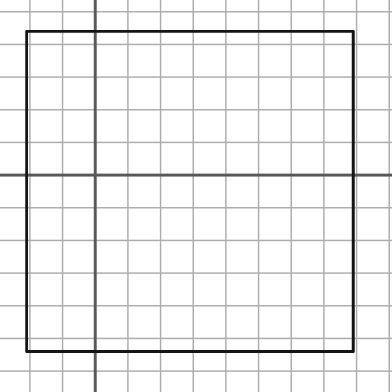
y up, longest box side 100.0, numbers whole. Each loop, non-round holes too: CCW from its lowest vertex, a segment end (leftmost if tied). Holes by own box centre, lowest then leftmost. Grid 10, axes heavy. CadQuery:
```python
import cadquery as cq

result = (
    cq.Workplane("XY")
    .moveTo(-21.0, -54.0)
    .lineTo(79.0, -54.0)
    .lineTo(79.0, 44.0)
    .lineTo(-21.0, 44.0)
    .close()
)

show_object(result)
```